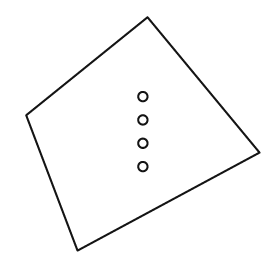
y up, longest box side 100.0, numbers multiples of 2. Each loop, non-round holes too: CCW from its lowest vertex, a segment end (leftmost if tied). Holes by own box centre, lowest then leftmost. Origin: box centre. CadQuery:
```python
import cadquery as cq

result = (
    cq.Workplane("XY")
    .moveTo(-28.0, -50.0)
    .lineTo(50.0, -8.0)
    .lineTo(2.0, 50.0)
    .lineTo(-50.0, 8.0)
    .close()
    .moveTo(0.0, -14.0)
    .circle(2.0)
    .moveTo(0.0, -4.0)
    .circle(2.0)
    .moveTo(0.0, 6.0)
    .circle(2.0)
    .moveTo(0.0, 16.0)
    .circle(2.0)
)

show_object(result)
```